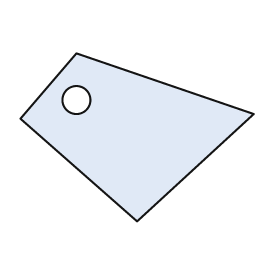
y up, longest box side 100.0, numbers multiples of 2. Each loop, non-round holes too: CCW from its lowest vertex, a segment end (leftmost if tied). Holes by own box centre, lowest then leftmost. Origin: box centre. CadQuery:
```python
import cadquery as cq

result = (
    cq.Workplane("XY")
    .moveTo(0.0, -36.0)
    .lineTo(50.0, 10.0)
    .lineTo(-26.0, 36.0)
    .lineTo(-50.0, 8.0)
    .close()
    .moveTo(-26.0, 16.0)
    .circle(6.0)
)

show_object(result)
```